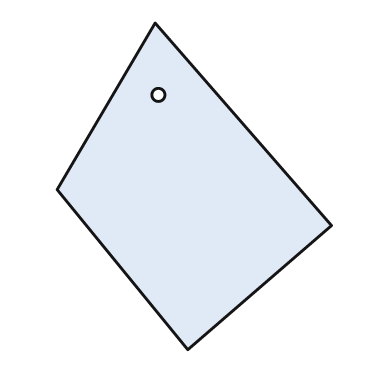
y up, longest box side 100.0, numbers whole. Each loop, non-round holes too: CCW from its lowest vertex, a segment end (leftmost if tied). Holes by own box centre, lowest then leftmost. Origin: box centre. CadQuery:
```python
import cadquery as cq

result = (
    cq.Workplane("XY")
    .moveTo(-2.0, -50.0)
    .lineTo(42.0, -12.0)
    .lineTo(-12.0, 50.0)
    .lineTo(-42.0, -1.0)
    .close()
    .moveTo(-11.0, 28.0)
    .circle(2.0)
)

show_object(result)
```